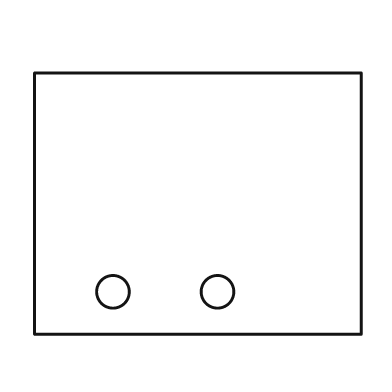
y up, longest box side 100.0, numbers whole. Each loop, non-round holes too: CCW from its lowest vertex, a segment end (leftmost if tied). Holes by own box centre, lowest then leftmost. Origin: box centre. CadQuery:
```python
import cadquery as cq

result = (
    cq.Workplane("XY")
    .moveTo(-50.0, -40.0)
    .lineTo(50.0, -40.0)
    .lineTo(50.0, 40.0)
    .lineTo(-50.0, 40.0)
    .close()
    .moveTo(-26.0, -27.0)
    .circle(5.0)
    .moveTo(6.0, -27.0)
    .circle(5.0)
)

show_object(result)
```